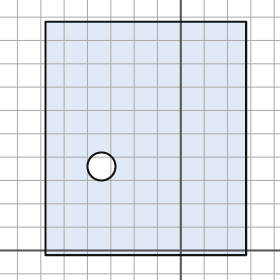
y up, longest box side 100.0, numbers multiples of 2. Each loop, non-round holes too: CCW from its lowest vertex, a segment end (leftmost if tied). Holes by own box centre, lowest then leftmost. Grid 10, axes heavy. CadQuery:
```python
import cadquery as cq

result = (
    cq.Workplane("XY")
    .moveTo(-58.0, -2.0)
    .lineTo(28.0, -2.0)
    .lineTo(28.0, 98.0)
    .lineTo(-58.0, 98.0)
    .close()
    .moveTo(-34.0, 36.0)
    .circle(6.0)
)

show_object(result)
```